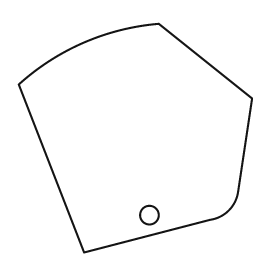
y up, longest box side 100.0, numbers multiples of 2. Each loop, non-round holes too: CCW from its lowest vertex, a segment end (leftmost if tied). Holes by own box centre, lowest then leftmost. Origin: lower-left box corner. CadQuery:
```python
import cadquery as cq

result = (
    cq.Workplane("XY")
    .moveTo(28.0, 0.0)
    .lineTo(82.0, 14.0)
    .threePointArc((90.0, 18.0), (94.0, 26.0))
    .lineTo(100.0, 66.0)
    .lineTo(60.0, 98.0)
    .threePointArc((28.0, 90.0), (0.0, 72.0))
    .close()
    .moveTo(56.0, 16.0)
    .circle(4.0)
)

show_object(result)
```